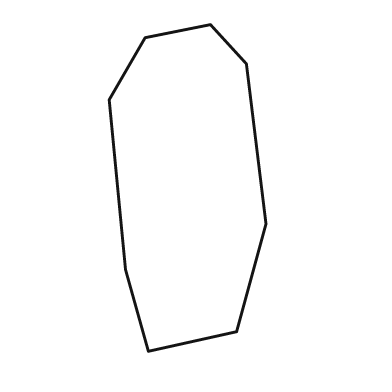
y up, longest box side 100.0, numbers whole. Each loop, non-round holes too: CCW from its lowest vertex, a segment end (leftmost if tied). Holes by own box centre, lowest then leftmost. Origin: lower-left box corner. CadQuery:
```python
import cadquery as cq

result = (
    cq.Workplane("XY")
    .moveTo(12.0, 0.0)
    .lineTo(39.0, 6.0)
    .lineTo(48.0, 39.0)
    .lineTo(42.0, 88.0)
    .lineTo(31.0, 100.0)
    .lineTo(11.0, 96.0)
    .lineTo(0.0, 77.0)
    .lineTo(5.0, 25.0)
    .close()
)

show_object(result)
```